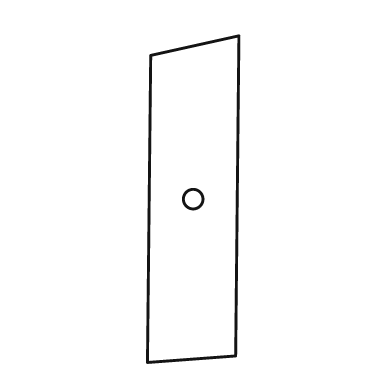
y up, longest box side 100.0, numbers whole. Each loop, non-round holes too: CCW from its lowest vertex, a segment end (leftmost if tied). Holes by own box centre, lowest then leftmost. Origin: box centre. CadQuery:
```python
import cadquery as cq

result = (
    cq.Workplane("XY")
    .moveTo(-14.0, -50.0)
    .lineTo(13.0, -48.0)
    .lineTo(14.0, 50.0)
    .lineTo(-13.0, 44.0)
    .close()
    .moveTo(0.0, 0.0)
    .circle(3.0)
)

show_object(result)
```